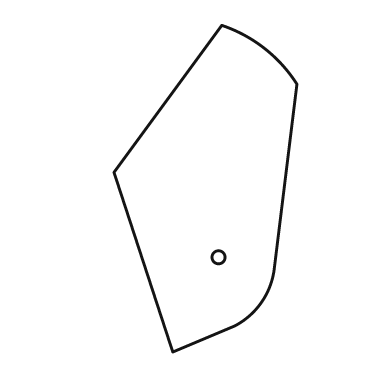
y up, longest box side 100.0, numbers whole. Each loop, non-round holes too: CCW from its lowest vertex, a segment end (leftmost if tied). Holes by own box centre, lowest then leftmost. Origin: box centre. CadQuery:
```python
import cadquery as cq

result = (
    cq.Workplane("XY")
    .moveTo(-10.0, -50.0)
    .lineTo(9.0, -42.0)
    .threePointArc((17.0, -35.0), (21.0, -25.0))
    .lineTo(28.0, 32.0)
    .threePointArc((18.0, 43.0), (5.0, 50.0))
    .lineTo(-28.0, 5.0)
    .close()
    .moveTo(4.0, -21.0)
    .circle(2.0)
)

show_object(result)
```